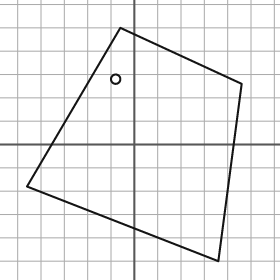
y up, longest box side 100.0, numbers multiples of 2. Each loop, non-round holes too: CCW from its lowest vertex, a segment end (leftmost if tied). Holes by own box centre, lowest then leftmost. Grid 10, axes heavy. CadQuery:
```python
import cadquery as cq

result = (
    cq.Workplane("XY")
    .moveTo(36.0, -50.0)
    .lineTo(46.0, 26.0)
    .lineTo(-6.0, 50.0)
    .lineTo(-46.0, -18.0)
    .close()
    .moveTo(-8.0, 28.0)
    .circle(2.0)
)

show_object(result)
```